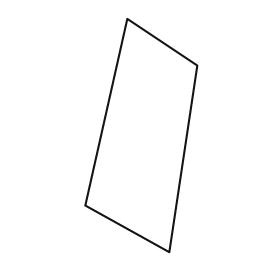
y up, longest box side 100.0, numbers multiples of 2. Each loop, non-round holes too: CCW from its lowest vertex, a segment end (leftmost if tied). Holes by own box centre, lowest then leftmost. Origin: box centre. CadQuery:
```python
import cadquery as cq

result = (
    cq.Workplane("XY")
    .moveTo(12.0, -50.0)
    .lineTo(24.0, 30.0)
    .lineTo(-6.0, 50.0)
    .lineTo(-24.0, -30.0)
    .close()
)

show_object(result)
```